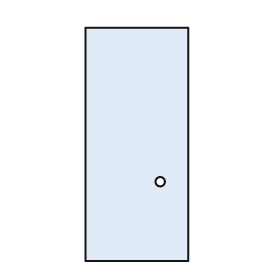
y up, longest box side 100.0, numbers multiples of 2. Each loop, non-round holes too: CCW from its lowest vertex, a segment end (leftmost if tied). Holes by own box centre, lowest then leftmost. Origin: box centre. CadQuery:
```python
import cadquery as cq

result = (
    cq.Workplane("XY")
    .moveTo(-22.0, -50.0)
    .lineTo(22.0, -50.0)
    .lineTo(22.0, 50.0)
    .lineTo(-22.0, 50.0)
    .close()
    .moveTo(10.0, -16.0)
    .circle(2.0)
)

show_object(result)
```